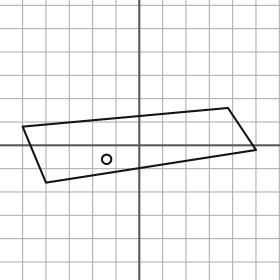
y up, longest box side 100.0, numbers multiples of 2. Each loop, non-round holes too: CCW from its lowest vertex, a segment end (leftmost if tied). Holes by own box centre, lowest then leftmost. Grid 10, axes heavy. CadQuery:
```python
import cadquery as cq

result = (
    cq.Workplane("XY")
    .moveTo(-40.0, -16.0)
    .lineTo(50.0, -2.0)
    .lineTo(38.0, 16.0)
    .lineTo(-50.0, 8.0)
    .close()
    .moveTo(-14.0, -6.0)
    .circle(2.0)
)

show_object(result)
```